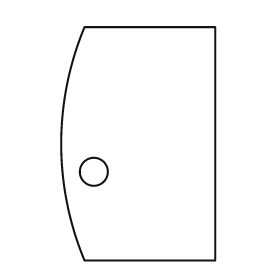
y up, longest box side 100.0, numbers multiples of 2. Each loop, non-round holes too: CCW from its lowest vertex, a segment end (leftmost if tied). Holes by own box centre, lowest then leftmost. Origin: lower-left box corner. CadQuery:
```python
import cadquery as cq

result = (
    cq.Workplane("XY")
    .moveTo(10.0, 0.0)
    .lineTo(66.0, 0.0)
    .lineTo(66.0, 100.0)
    .lineTo(10.0, 100.0)
    .threePointArc((0.0, 50.0), (10.0, 0.0))
    .close()
    .moveTo(14.0, 38.0)
    .circle(6.0)
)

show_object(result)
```